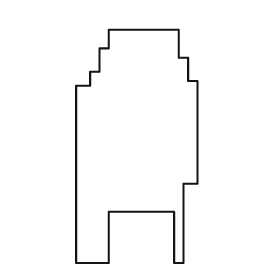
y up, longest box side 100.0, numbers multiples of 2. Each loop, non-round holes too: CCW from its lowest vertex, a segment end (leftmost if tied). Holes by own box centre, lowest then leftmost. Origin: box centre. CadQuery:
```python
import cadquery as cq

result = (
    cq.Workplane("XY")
    .moveTo(-26.0, -50.0)
    .lineTo(-12.0, -50.0)
    .lineTo(-12.0, -28.0)
    .lineTo(16.0, -28.0)
    .lineTo(16.0, -50.0)
    .lineTo(20.0, -50.0)
    .lineTo(20.0, -16.0)
    .lineTo(26.0, -16.0)
    .lineTo(26.0, 28.0)
    .lineTo(22.0, 28.0)
    .lineTo(22.0, 38.0)
    .lineTo(18.0, 38.0)
    .lineTo(18.0, 50.0)
    .lineTo(-12.0, 50.0)
    .lineTo(-12.0, 42.0)
    .lineTo(-16.0, 42.0)
    .lineTo(-16.0, 32.0)
    .lineTo(-20.0, 32.0)
    .lineTo(-20.0, 26.0)
    .lineTo(-26.0, 26.0)
    .close()
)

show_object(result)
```